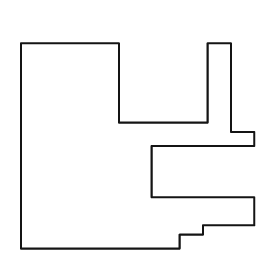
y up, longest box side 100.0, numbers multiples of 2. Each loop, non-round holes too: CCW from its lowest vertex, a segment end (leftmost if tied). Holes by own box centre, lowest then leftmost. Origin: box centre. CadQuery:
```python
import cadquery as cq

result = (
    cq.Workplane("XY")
    .moveTo(-50.0, -44.0)
    .lineTo(18.0, -44.0)
    .lineTo(18.0, -38.0)
    .lineTo(28.0, -38.0)
    .lineTo(28.0, -34.0)
    .lineTo(50.0, -34.0)
    .lineTo(50.0, -22.0)
    .lineTo(6.0, -22.0)
    .lineTo(6.0, 0.0)
    .lineTo(50.0, 0.0)
    .lineTo(50.0, 6.0)
    .lineTo(40.0, 6.0)
    .lineTo(40.0, 44.0)
    .lineTo(30.0, 44.0)
    .lineTo(30.0, 10.0)
    .lineTo(-8.0, 10.0)
    .lineTo(-8.0, 44.0)
    .lineTo(-50.0, 44.0)
    .close()
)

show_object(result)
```